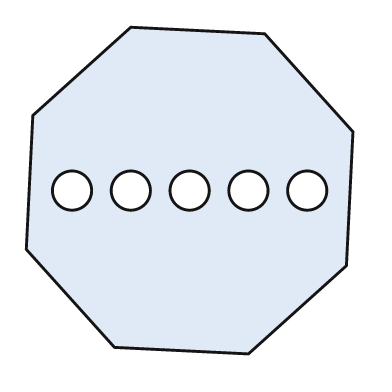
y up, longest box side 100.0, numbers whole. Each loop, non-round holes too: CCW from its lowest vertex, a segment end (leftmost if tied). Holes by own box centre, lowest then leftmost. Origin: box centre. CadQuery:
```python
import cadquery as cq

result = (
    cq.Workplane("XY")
    .moveTo(18.0, -50.0)
    .lineTo(48.0, -23.0)
    .lineTo(50.0, 18.0)
    .lineTo(23.0, 48.0)
    .lineTo(-18.0, 50.0)
    .lineTo(-48.0, 23.0)
    .lineTo(-50.0, -18.0)
    .lineTo(-23.0, -48.0)
    .close()
    .moveTo(-36.0, 0.0)
    .circle(6.0)
    .moveTo(-18.0, 0.0)
    .circle(6.0)
    .moveTo(0.0, 0.0)
    .circle(6.0)
    .moveTo(18.0, 0.0)
    .circle(6.0)
    .moveTo(36.0, 0.0)
    .circle(6.0)
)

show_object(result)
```